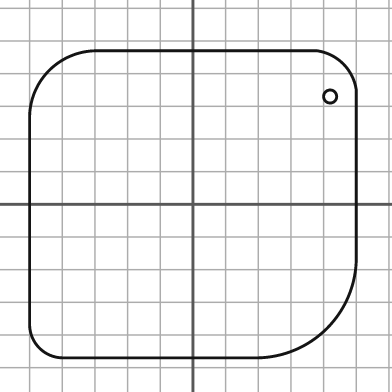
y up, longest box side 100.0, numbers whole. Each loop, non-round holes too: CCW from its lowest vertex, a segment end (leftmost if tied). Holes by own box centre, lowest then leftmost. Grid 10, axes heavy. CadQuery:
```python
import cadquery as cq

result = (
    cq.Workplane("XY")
    .moveTo(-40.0, -47.0)
    .lineTo(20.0, -47.0)
    .threePointArc((41.0, -38.0), (50.0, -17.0))
    .lineTo(50.0, 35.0)
    .threePointArc((46.0, 43.0), (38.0, 47.0))
    .lineTo(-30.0, 47.0)
    .threePointArc((-44.0, 41.0), (-50.0, 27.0))
    .lineTo(-50.0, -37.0)
    .threePointArc((-47.0, -44.0), (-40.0, -47.0))
    .close()
    .moveTo(42.0, 33.0)
    .circle(2.0)
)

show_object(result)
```